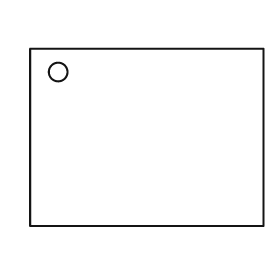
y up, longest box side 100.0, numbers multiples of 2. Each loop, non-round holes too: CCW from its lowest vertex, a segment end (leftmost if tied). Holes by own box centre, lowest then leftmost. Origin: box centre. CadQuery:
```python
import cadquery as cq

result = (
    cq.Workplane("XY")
    .moveTo(-50.0, -38.0)
    .lineTo(50.0, -38.0)
    .lineTo(50.0, 38.0)
    .lineTo(-50.0, 38.0)
    .close()
    .moveTo(-38.0, 28.0)
    .circle(4.0)
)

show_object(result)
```